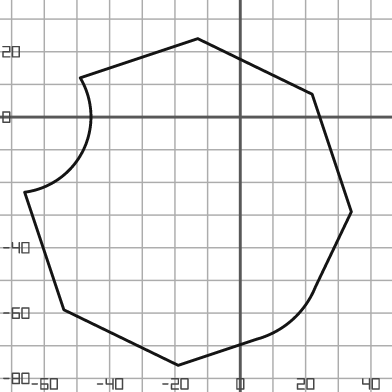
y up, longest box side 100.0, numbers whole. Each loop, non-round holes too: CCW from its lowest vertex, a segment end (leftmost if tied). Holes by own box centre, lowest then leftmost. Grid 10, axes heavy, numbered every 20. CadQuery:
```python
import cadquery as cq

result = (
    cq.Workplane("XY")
    .moveTo(-19.0, -76.0)
    .lineTo(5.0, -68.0)
    .threePointArc((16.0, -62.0), (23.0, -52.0))
    .lineTo(34.0, -29.0)
    .lineTo(22.0, 7.0)
    .lineTo(-13.0, 24.0)
    .lineTo(-49.0, 12.0)
    .threePointArc((-48.0, -10.0), (-66.0, -23.0))
    .lineTo(-54.0, -59.0)
    .close()
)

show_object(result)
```